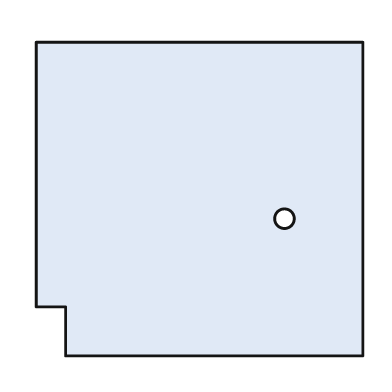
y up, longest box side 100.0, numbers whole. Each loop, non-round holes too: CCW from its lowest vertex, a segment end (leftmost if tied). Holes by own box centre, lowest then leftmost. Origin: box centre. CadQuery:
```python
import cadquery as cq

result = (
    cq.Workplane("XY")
    .moveTo(-41.0, -48.0)
    .lineTo(50.0, -48.0)
    .lineTo(50.0, 48.0)
    .lineTo(-50.0, 48.0)
    .lineTo(-50.0, -33.0)
    .lineTo(-41.0, -33.0)
    .close()
    .moveTo(26.0, -6.0)
    .circle(3.0)
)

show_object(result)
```